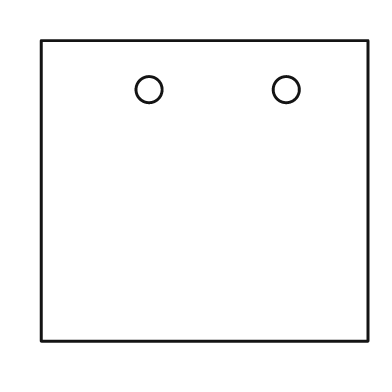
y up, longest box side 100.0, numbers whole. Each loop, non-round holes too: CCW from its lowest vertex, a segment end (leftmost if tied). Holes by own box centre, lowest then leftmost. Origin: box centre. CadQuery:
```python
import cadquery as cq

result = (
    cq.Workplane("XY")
    .moveTo(-50.0, -46.0)
    .lineTo(50.0, -46.0)
    .lineTo(50.0, 46.0)
    .lineTo(-50.0, 46.0)
    .close()
    .moveTo(-17.0, 31.0)
    .circle(4.0)
    .moveTo(25.0, 31.0)
    .circle(4.0)
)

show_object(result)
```